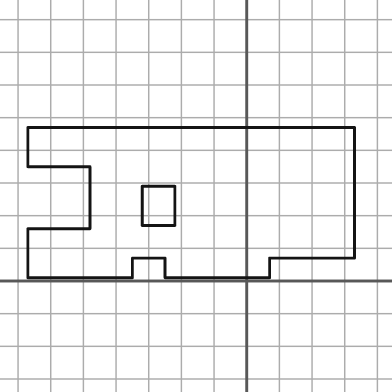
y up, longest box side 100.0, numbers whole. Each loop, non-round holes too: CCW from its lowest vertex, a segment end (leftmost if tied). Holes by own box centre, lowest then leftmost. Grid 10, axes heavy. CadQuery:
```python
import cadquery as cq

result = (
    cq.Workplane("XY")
    .moveTo(-67.0, 1.0)
    .lineTo(-35.0, 1.0)
    .lineTo(-35.0, 7.0)
    .lineTo(-25.0, 7.0)
    .lineTo(-25.0, 1.0)
    .lineTo(7.0, 1.0)
    .lineTo(7.0, 7.0)
    .lineTo(33.0, 7.0)
    .lineTo(33.0, 47.0)
    .lineTo(-67.0, 47.0)
    .lineTo(-67.0, 35.0)
    .lineTo(-48.0, 35.0)
    .lineTo(-48.0, 16.0)
    .lineTo(-67.0, 16.0)
    .close()
    .moveTo(-32.0, 17.0)
    .lineTo(-22.0, 17.0)
    .lineTo(-22.0, 29.0)
    .lineTo(-32.0, 29.0)
    .close()
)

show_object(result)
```